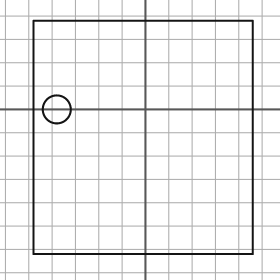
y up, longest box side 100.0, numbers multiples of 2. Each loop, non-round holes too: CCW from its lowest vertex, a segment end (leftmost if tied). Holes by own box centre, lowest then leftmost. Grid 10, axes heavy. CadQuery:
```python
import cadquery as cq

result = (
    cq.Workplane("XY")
    .moveTo(-48.0, -62.0)
    .lineTo(46.0, -62.0)
    .lineTo(46.0, 38.0)
    .lineTo(-48.0, 38.0)
    .close()
    .moveTo(-38.0, 0.0)
    .circle(6.0)
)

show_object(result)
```